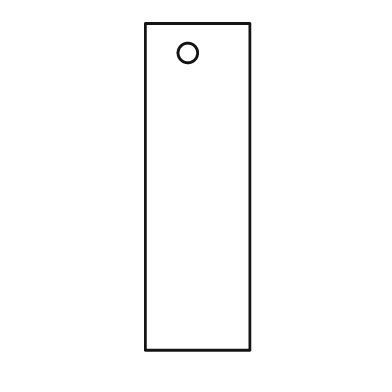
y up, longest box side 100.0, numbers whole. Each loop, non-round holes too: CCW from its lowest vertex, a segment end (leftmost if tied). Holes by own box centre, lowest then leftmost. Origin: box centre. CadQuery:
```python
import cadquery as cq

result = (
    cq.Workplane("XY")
    .moveTo(-16.0, -50.0)
    .lineTo(16.0, -50.0)
    .lineTo(16.0, 50.0)
    .lineTo(-16.0, 50.0)
    .close()
    .moveTo(-3.0, 41.0)
    .circle(3.0)
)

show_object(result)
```